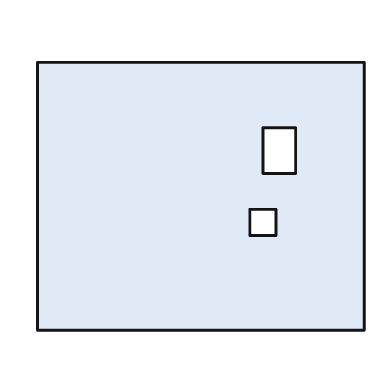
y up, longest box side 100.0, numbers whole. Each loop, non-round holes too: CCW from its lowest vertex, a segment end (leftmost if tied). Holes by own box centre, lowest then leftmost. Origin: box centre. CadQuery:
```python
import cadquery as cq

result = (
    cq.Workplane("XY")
    .moveTo(-50.0, -41.0)
    .lineTo(50.0, -41.0)
    .lineTo(50.0, 41.0)
    .lineTo(-50.0, 41.0)
    .close()
    .moveTo(15.0, -12.0)
    .lineTo(23.0, -12.0)
    .lineTo(23.0, -4.0)
    .lineTo(15.0, -4.0)
    .close()
    .moveTo(19.0, 7.0)
    .lineTo(29.0, 7.0)
    .lineTo(29.0, 21.0)
    .lineTo(19.0, 21.0)
    .close()
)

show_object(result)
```